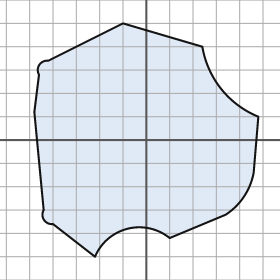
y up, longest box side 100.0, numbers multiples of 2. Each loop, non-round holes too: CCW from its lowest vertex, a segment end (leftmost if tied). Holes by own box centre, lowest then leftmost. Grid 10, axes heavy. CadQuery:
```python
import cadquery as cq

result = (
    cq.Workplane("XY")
    .moveTo(-22.0, -50.0)
    .threePointArc((-8.0, -38.0), (10.0, -42.0))
    .lineTo(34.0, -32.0)
    .threePointArc((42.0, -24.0), (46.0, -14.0))
    .lineTo(48.0, 10.0)
    .threePointArc((32.0, 22.0), (24.0, 40.0))
    .lineTo(-10.0, 50.0)
    .lineTo(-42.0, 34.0)
    .threePointArc((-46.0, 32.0), (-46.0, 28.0))
    .lineTo(-48.0, 12.0)
    .lineTo(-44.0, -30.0)
    .threePointArc((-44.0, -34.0), (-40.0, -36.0))
    .close()
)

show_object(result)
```